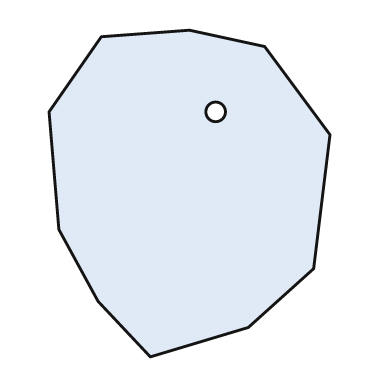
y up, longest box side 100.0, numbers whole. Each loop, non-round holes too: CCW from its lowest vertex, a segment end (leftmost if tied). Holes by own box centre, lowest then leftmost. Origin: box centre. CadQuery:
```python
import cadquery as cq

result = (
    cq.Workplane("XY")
    .moveTo(-12.0, -50.0)
    .lineTo(18.0, -41.0)
    .lineTo(38.0, -23.0)
    .lineTo(43.0, 18.0)
    .lineTo(23.0, 45.0)
    .lineTo(0.0, 50.0)
    .lineTo(-27.0, 48.0)
    .lineTo(-43.0, 25.0)
    .lineTo(-40.0, -11.0)
    .lineTo(-28.0, -33.0)
    .close()
    .moveTo(8.0, 25.0)
    .circle(3.0)
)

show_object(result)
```